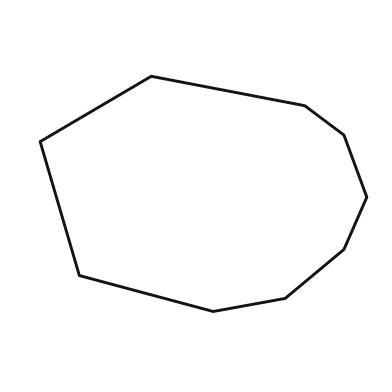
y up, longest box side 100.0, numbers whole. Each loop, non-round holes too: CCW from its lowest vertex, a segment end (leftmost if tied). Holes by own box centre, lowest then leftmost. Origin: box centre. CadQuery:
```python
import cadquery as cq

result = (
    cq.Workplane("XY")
    .moveTo(3.0, -36.0)
    .lineTo(25.0, -32.0)
    .lineTo(43.0, -17.0)
    .lineTo(50.0, -1.0)
    .lineTo(43.0, 18.0)
    .lineTo(31.0, 27.0)
    .lineTo(-16.0, 36.0)
    .lineTo(-50.0, 16.0)
    .lineTo(-38.0, -25.0)
    .close()
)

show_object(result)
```